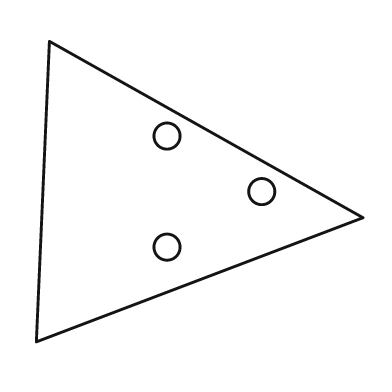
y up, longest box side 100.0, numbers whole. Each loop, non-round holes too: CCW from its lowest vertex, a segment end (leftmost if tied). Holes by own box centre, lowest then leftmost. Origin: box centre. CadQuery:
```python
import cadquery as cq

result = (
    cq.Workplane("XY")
    .moveTo(-50.0, -46.0)
    .lineTo(50.0, -8.0)
    .lineTo(-46.0, 46.0)
    .close()
    .moveTo(-10.0, -17.0)
    .circle(4.0)
    .moveTo(19.0, 0.0)
    .circle(4.0)
    .moveTo(-10.0, 17.0)
    .circle(4.0)
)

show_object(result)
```